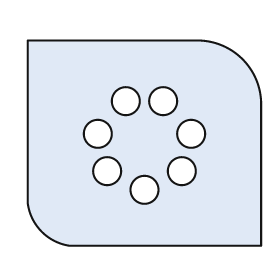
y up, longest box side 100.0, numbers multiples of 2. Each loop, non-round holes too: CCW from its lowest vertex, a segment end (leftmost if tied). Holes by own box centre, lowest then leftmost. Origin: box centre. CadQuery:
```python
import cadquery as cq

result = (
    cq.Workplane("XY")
    .moveTo(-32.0, -44.0)
    .lineTo(50.0, -44.0)
    .lineTo(50.0, 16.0)
    .threePointArc((42.0, 36.0), (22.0, 44.0))
    .lineTo(-50.0, 44.0)
    .lineTo(-50.0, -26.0)
    .threePointArc((-44.0, -38.0), (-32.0, -44.0))
    .close()
    .moveTo(0.0, -20.0)
    .circle(6.0)
    .moveTo(-16.0, -12.0)
    .circle(6.0)
    .moveTo(16.0, -12.0)
    .circle(6.0)
    .moveTo(-20.0, 4.0)
    .circle(6.0)
    .moveTo(20.0, 4.0)
    .circle(6.0)
    .moveTo(-8.0, 18.0)
    .circle(6.0)
    .moveTo(8.0, 18.0)
    .circle(6.0)
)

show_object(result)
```